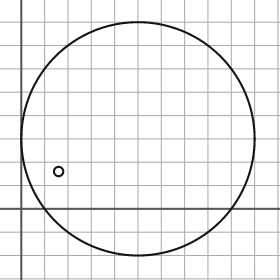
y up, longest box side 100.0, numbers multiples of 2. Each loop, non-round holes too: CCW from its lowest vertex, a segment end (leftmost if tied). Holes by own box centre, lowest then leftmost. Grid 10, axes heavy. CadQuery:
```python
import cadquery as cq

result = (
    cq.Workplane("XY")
    .moveTo(50.0, 30.0)
    .circle(50.0)
    .moveTo(16.0, 16.0)
    .circle(2.0)
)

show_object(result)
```